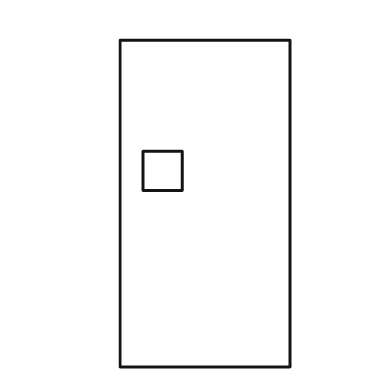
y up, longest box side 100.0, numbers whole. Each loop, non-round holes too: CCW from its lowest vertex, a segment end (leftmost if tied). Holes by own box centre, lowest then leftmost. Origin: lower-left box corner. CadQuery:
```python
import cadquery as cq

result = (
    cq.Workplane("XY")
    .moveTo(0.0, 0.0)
    .lineTo(52.0, 0.0)
    .lineTo(52.0, 100.0)
    .lineTo(0.0, 100.0)
    .close()
    .moveTo(7.0, 54.0)
    .lineTo(19.0, 54.0)
    .lineTo(19.0, 66.0)
    .lineTo(7.0, 66.0)
    .close()
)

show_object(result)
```